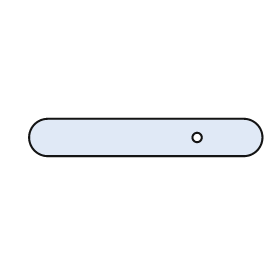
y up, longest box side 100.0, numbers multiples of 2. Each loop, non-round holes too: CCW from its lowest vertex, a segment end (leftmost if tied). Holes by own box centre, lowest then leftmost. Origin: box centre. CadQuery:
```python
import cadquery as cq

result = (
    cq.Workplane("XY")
    .moveTo(-42.0, -8.0)
    .lineTo(42.0, -8.0)
    .threePointArc((50.0, 0.0), (42.0, 8.0))
    .lineTo(-42.0, 8.0)
    .threePointArc((-50.0, 0.0), (-42.0, -8.0))
    .close()
    .moveTo(22.0, 0.0)
    .circle(2.0)
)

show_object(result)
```